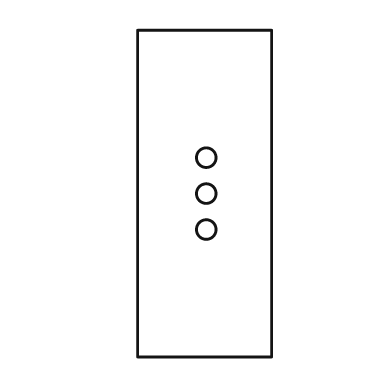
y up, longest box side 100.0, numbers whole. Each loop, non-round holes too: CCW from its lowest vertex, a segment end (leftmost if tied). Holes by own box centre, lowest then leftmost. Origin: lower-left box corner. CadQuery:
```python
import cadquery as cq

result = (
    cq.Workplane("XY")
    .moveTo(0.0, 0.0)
    .lineTo(41.0, 0.0)
    .lineTo(41.0, 100.0)
    .lineTo(0.0, 100.0)
    .close()
    .moveTo(21.0, 39.0)
    .circle(3.0)
    .moveTo(21.0, 50.0)
    .circle(3.0)
    .moveTo(21.0, 61.0)
    .circle(3.0)
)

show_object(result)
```